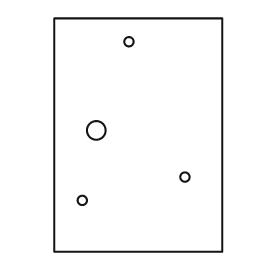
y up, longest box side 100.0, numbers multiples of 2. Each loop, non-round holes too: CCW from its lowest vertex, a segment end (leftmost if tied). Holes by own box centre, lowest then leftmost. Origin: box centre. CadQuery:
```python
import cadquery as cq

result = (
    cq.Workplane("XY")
    .moveTo(-36.0, -50.0)
    .lineTo(36.0, -50.0)
    .lineTo(36.0, 50.0)
    .lineTo(-36.0, 50.0)
    .close()
    .moveTo(-24.0, -28.0)
    .circle(2.0)
    .moveTo(20.0, -18.0)
    .circle(2.0)
    .moveTo(-18.0, 2.0)
    .circle(4.0)
    .moveTo(-4.0, 40.0)
    .circle(2.0)
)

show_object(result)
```